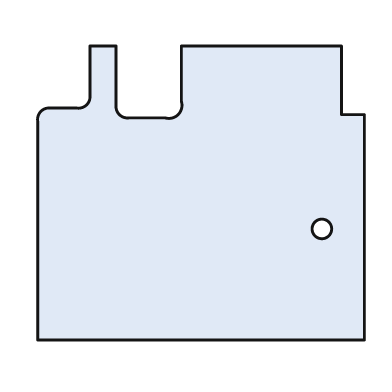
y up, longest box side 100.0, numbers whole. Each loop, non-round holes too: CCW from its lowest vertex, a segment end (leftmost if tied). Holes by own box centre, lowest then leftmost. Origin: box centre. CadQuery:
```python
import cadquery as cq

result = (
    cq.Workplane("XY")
    .moveTo(-50.0, -45.0)
    .lineTo(50.0, -45.0)
    .lineTo(50.0, 24.0)
    .lineTo(43.0, 24.0)
    .lineTo(43.0, 45.0)
    .lineTo(-6.0, 45.0)
    .lineTo(-6.0, 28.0)
    .threePointArc((-7.0, 24.0), (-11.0, 23.0))
    .lineTo(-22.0, 23.0)
    .threePointArc((-25.0, 24.0), (-26.0, 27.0))
    .lineTo(-26.0, 45.0)
    .lineTo(-34.0, 45.0)
    .lineTo(-34.0, 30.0)
    .threePointArc((-35.0, 27.0), (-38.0, 26.0))
    .lineTo(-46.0, 26.0)
    .threePointArc((-49.0, 25.0), (-50.0, 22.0))
    .close()
    .moveTo(37.0, -11.0)
    .circle(3.0)
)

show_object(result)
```